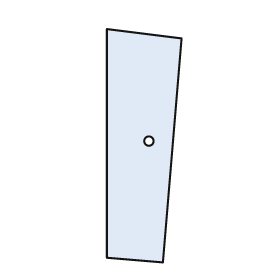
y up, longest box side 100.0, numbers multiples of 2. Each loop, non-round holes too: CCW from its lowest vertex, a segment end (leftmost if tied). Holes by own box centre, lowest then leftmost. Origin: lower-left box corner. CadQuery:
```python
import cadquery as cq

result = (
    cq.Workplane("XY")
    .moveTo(24.0, 0.0)
    .lineTo(32.0, 96.0)
    .lineTo(0.0, 100.0)
    .lineTo(0.0, 2.0)
    .close()
    .moveTo(18.0, 52.0)
    .circle(2.0)
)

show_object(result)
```